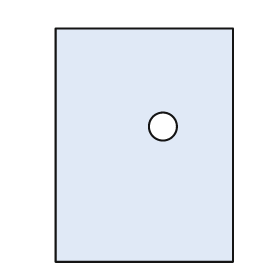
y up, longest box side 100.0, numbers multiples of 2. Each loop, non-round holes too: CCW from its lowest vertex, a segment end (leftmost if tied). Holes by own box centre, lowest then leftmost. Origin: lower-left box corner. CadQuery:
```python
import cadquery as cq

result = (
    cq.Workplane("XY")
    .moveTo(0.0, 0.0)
    .lineTo(76.0, 0.0)
    .lineTo(76.0, 100.0)
    .lineTo(0.0, 100.0)
    .close()
    .moveTo(46.0, 58.0)
    .circle(6.0)
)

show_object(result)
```